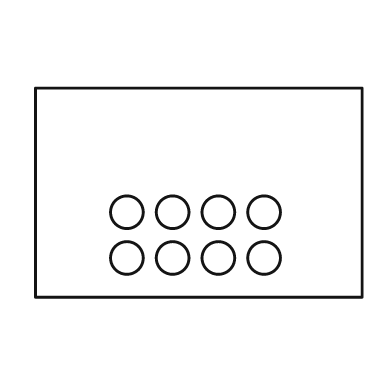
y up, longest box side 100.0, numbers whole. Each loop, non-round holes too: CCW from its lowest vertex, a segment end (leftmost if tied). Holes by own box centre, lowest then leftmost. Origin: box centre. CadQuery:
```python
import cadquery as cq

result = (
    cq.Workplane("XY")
    .moveTo(-50.0, -32.0)
    .lineTo(50.0, -32.0)
    .lineTo(50.0, 32.0)
    .lineTo(-50.0, 32.0)
    .close()
    .moveTo(-22.0, -20.0)
    .circle(5.0)
    .moveTo(-8.0, -20.0)
    .circle(5.0)
    .moveTo(6.0, -20.0)
    .circle(5.0)
    .moveTo(20.0, -20.0)
    .circle(5.0)
    .moveTo(-22.0, -6.0)
    .circle(5.0)
    .moveTo(-8.0, -6.0)
    .circle(5.0)
    .moveTo(6.0, -6.0)
    .circle(5.0)
    .moveTo(20.0, -6.0)
    .circle(5.0)
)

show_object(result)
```